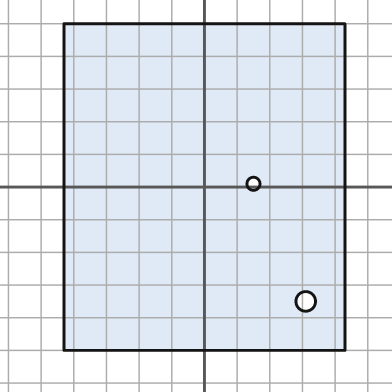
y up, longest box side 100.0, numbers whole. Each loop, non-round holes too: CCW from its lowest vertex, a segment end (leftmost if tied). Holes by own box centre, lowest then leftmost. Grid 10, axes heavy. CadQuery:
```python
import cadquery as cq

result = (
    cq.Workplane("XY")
    .moveTo(-43.0, -50.0)
    .lineTo(43.0, -50.0)
    .lineTo(43.0, 50.0)
    .lineTo(-43.0, 50.0)
    .close()
    .moveTo(31.0, -35.0)
    .circle(3.0)
    .moveTo(15.0, 1.0)
    .circle(2.0)
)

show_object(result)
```